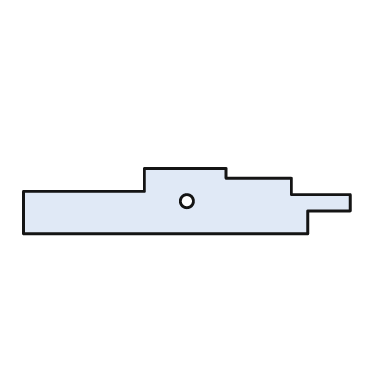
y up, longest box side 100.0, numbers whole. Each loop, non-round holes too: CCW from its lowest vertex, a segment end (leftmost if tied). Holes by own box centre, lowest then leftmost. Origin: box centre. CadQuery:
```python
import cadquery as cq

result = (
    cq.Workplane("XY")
    .moveTo(-50.0, -10.0)
    .lineTo(37.0, -10.0)
    .lineTo(37.0, -3.0)
    .lineTo(50.0, -3.0)
    .lineTo(50.0, 2.0)
    .lineTo(32.0, 2.0)
    .lineTo(32.0, 7.0)
    .lineTo(12.0, 7.0)
    .lineTo(12.0, 10.0)
    .lineTo(-13.0, 10.0)
    .lineTo(-13.0, 3.0)
    .lineTo(-50.0, 3.0)
    .close()
    .moveTo(0.0, 0.0)
    .circle(2.0)
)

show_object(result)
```